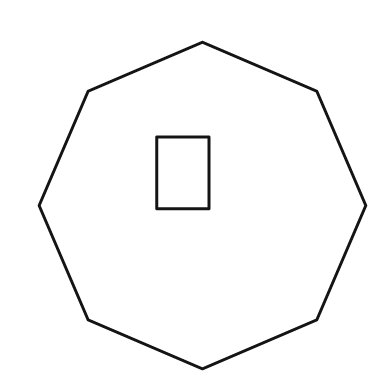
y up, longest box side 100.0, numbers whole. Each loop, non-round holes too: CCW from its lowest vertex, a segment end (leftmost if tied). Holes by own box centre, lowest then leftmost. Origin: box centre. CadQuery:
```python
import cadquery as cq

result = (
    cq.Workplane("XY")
    .moveTo(0.0, -50.0)
    .lineTo(35.0, -35.0)
    .lineTo(50.0, 0.0)
    .lineTo(35.0, 35.0)
    .lineTo(0.0, 50.0)
    .lineTo(-35.0, 35.0)
    .lineTo(-50.0, 0.0)
    .lineTo(-35.0, -35.0)
    .close()
    .moveTo(-14.0, -1.0)
    .lineTo(2.0, -1.0)
    .lineTo(2.0, 21.0)
    .lineTo(-14.0, 21.0)
    .close()
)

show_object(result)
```